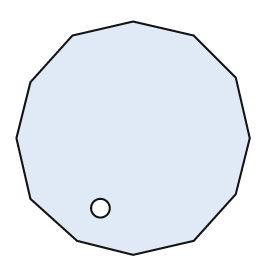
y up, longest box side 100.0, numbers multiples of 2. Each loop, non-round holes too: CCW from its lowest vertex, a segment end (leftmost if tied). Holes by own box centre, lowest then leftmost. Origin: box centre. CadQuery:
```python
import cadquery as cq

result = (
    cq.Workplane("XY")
    .moveTo(0.0, -50.0)
    .lineTo(26.0, -44.0)
    .lineTo(44.0, -24.0)
    .lineTo(50.0, 0.0)
    .lineTo(44.0, 26.0)
    .lineTo(26.0, 44.0)
    .lineTo(0.0, 50.0)
    .lineTo(-26.0, 44.0)
    .lineTo(-44.0, 24.0)
    .lineTo(-50.0, 0.0)
    .lineTo(-44.0, -26.0)
    .lineTo(-24.0, -44.0)
    .close()
    .moveTo(-14.0, -30.0)
    .circle(4.0)
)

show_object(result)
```